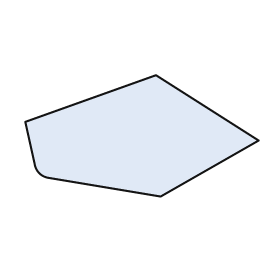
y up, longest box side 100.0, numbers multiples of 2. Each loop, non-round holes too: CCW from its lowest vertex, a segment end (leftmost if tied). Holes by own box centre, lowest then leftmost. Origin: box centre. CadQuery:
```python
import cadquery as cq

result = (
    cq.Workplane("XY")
    .moveTo(8.0, -26.0)
    .lineTo(50.0, -2.0)
    .lineTo(6.0, 26.0)
    .lineTo(-50.0, 6.0)
    .lineTo(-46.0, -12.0)
    .threePointArc((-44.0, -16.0), (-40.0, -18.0))
    .close()
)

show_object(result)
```